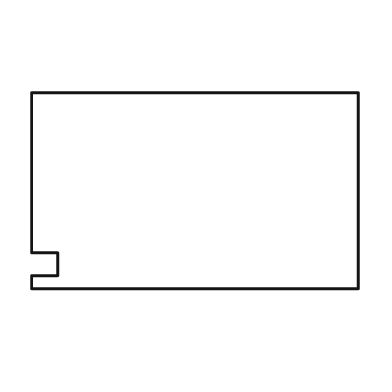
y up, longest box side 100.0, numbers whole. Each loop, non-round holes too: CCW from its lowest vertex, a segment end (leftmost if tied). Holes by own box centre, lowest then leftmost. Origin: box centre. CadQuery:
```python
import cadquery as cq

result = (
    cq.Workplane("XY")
    .moveTo(-50.0, -30.0)
    .lineTo(50.0, -30.0)
    .lineTo(50.0, 30.0)
    .lineTo(-50.0, 30.0)
    .lineTo(-50.0, -19.0)
    .lineTo(-42.0, -19.0)
    .lineTo(-42.0, -26.0)
    .lineTo(-50.0, -26.0)
    .close()
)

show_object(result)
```